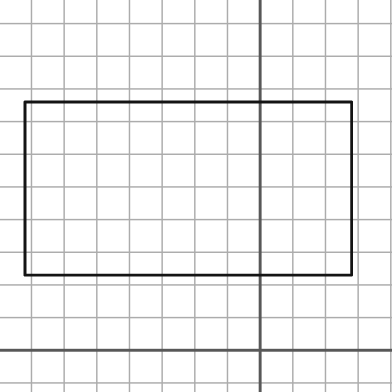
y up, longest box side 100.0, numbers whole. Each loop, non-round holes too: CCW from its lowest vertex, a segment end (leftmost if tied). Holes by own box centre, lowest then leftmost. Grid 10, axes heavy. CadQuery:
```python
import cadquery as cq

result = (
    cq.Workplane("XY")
    .moveTo(-72.0, 23.0)
    .lineTo(28.0, 23.0)
    .lineTo(28.0, 76.0)
    .lineTo(-72.0, 76.0)
    .close()
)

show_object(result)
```